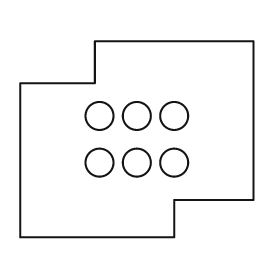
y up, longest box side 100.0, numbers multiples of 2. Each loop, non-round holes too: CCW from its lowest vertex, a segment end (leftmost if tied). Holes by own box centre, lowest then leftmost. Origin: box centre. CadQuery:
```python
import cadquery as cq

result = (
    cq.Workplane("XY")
    .moveTo(-50.0, -42.0)
    .lineTo(16.0, -42.0)
    .lineTo(16.0, -26.0)
    .lineTo(50.0, -26.0)
    .lineTo(50.0, 42.0)
    .lineTo(-18.0, 42.0)
    .lineTo(-18.0, 24.0)
    .lineTo(-50.0, 24.0)
    .close()
    .moveTo(-16.0, -10.0)
    .circle(6.0)
    .moveTo(0.0, -10.0)
    .circle(6.0)
    .moveTo(16.0, -10.0)
    .circle(6.0)
    .moveTo(-16.0, 10.0)
    .circle(6.0)
    .moveTo(0.0, 10.0)
    .circle(6.0)
    .moveTo(16.0, 10.0)
    .circle(6.0)
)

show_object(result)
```